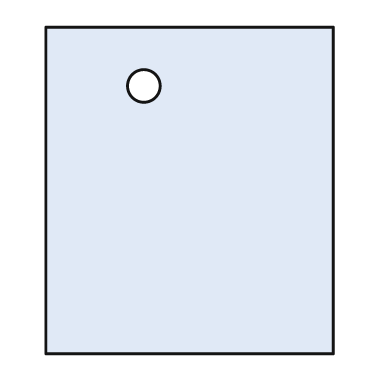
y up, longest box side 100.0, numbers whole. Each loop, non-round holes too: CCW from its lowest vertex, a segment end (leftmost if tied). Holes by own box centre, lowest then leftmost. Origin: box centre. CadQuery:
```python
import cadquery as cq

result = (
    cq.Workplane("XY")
    .moveTo(-44.0, -50.0)
    .lineTo(44.0, -50.0)
    .lineTo(44.0, 50.0)
    .lineTo(-44.0, 50.0)
    .close()
    .moveTo(-14.0, 32.0)
    .circle(5.0)
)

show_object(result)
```